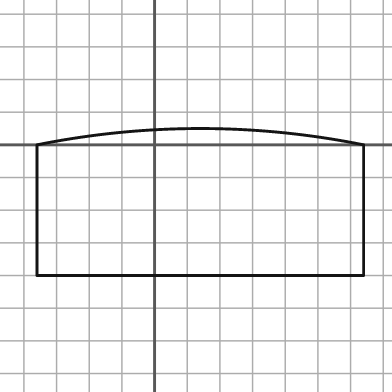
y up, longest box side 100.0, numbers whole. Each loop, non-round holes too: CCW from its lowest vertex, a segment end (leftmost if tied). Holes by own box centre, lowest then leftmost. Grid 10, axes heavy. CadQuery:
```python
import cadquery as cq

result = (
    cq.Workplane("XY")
    .moveTo(-36.0, -40.0)
    .lineTo(64.0, -40.0)
    .lineTo(64.0, 0.0)
    .threePointArc((14.0, 5.0), (-36.0, 0.0))
    .close()
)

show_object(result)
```